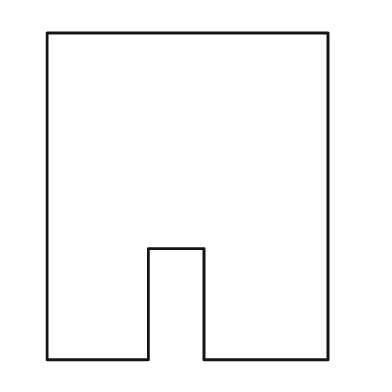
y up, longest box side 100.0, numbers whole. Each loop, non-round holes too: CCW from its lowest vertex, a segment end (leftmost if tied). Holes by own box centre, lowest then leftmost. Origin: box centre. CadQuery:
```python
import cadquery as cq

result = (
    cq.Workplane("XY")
    .moveTo(-43.0, -50.0)
    .lineTo(-12.0, -50.0)
    .lineTo(-12.0, -16.0)
    .lineTo(5.0, -16.0)
    .lineTo(5.0, -50.0)
    .lineTo(43.0, -50.0)
    .lineTo(43.0, 50.0)
    .lineTo(-43.0, 50.0)
    .close()
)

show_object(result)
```